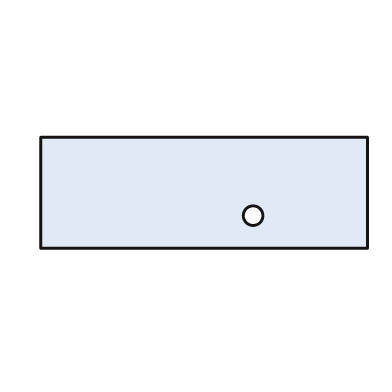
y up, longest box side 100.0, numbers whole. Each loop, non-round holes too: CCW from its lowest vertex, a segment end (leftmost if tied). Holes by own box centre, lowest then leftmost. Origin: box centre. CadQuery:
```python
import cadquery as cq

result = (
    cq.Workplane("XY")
    .moveTo(-50.0, -17.0)
    .lineTo(50.0, -17.0)
    .lineTo(50.0, 17.0)
    .lineTo(-50.0, 17.0)
    .close()
    .moveTo(15.0, -7.0)
    .circle(3.0)
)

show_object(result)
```